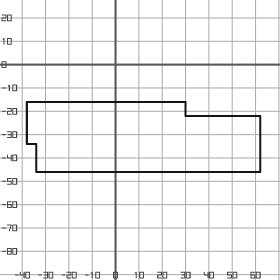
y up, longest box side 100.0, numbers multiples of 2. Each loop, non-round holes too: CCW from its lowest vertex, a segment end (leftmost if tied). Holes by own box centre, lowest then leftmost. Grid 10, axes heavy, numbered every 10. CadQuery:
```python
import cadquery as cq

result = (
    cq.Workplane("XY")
    .moveTo(-34.0, -46.0)
    .lineTo(62.0, -46.0)
    .lineTo(62.0, -22.0)
    .lineTo(30.0, -22.0)
    .lineTo(30.0, -16.0)
    .lineTo(-38.0, -16.0)
    .lineTo(-38.0, -34.0)
    .lineTo(-34.0, -34.0)
    .close()
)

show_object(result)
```